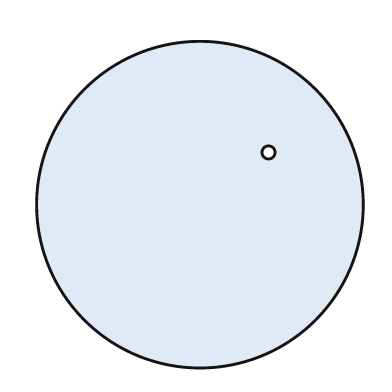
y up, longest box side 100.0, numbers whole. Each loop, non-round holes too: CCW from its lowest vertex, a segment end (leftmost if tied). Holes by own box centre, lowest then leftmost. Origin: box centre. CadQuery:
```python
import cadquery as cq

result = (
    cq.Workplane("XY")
    .moveTo(0.0, 0.0)
    .circle(50.0)
    .moveTo(21.0, 16.0)
    .circle(2.0)
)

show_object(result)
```